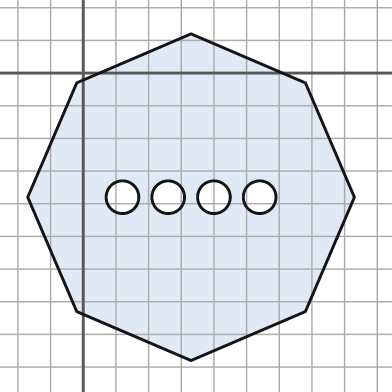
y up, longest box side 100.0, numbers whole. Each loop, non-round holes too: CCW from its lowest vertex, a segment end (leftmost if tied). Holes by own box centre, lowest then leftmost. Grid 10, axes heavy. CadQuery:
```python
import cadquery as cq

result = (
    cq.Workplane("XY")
    .moveTo(33.0, -88.0)
    .lineTo(68.0, -73.0)
    .lineTo(83.0, -38.0)
    .lineTo(68.0, -3.0)
    .lineTo(33.0, 12.0)
    .lineTo(-2.0, -3.0)
    .lineTo(-17.0, -38.0)
    .lineTo(-2.0, -73.0)
    .close()
    .moveTo(12.0, -38.0)
    .circle(5.0)
    .moveTo(26.0, -38.0)
    .circle(5.0)
    .moveTo(40.0, -38.0)
    .circle(5.0)
    .moveTo(54.0, -38.0)
    .circle(5.0)
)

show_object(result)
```